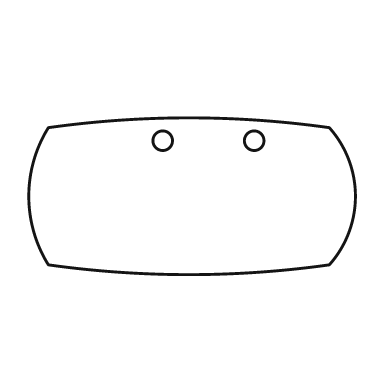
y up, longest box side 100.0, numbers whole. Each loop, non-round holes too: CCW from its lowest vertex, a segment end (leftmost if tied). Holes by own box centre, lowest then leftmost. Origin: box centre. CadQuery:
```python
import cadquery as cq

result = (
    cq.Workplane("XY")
    .moveTo(-44.0, -21.0)
    .threePointArc((-1.0, -24.0), (42.0, -21.0))
    .threePointArc((50.0, 0.0), (42.0, 21.0))
    .threePointArc((-1.0, 24.0), (-44.0, 21.0))
    .threePointArc((-50.0, 0.0), (-44.0, -21.0))
    .close()
    .moveTo(-9.0, 17.0)
    .circle(3.0)
    .moveTo(19.0, 17.0)
    .circle(3.0)
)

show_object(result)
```